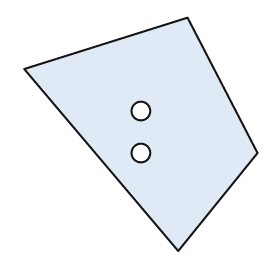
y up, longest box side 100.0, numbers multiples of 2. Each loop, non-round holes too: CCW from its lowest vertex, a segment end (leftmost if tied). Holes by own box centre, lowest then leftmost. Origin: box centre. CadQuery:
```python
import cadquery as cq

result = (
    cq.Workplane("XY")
    .moveTo(16.0, -50.0)
    .lineTo(50.0, -8.0)
    .lineTo(20.0, 50.0)
    .lineTo(-50.0, 28.0)
    .close()
    .moveTo(0.0, -8.0)
    .circle(4.0)
    .moveTo(0.0, 10.0)
    .circle(4.0)
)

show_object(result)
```